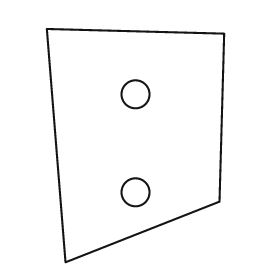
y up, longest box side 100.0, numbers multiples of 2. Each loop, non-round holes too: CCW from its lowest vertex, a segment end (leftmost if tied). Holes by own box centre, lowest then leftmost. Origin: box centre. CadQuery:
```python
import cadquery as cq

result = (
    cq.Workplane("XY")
    .moveTo(-30.0, -50.0)
    .lineTo(36.0, -24.0)
    .lineTo(38.0, 48.0)
    .lineTo(-38.0, 50.0)
    .close()
    .moveTo(0.0, -20.0)
    .circle(6.0)
    .moveTo(0.0, 22.0)
    .circle(6.0)
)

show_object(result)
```